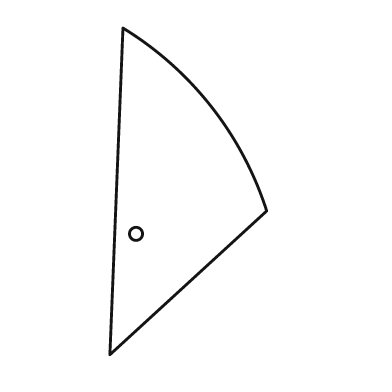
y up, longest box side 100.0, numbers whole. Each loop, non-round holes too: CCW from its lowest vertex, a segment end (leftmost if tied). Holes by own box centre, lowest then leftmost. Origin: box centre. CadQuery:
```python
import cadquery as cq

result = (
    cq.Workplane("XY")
    .moveTo(-24.0, -50.0)
    .lineTo(24.0, -6.0)
    .threePointArc((7.0, 26.0), (-20.0, 50.0))
    .close()
    .moveTo(-16.0, -13.0)
    .circle(2.0)
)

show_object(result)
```